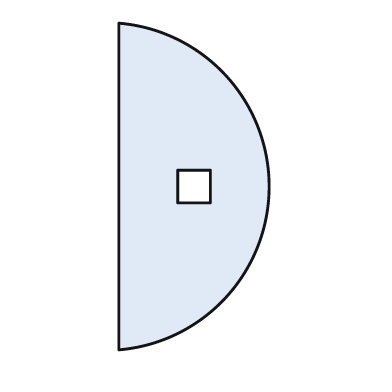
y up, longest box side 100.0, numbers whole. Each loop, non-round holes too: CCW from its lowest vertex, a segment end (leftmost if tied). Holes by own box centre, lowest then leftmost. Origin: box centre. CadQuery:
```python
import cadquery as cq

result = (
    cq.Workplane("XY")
    .moveTo(-23.0, -50.0)
    .threePointArc((23.0, 0.0), (-23.0, 50.0))
    .close()
    .moveTo(-5.0, -5.0)
    .lineTo(5.0, -5.0)
    .lineTo(5.0, 5.0)
    .lineTo(-5.0, 5.0)
    .close()
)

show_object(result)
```